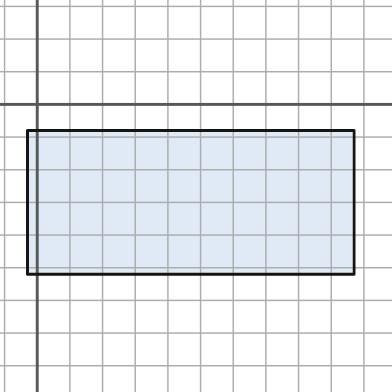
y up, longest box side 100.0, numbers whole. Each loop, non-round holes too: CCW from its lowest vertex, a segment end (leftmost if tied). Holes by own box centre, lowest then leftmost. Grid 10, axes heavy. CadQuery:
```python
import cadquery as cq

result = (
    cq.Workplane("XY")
    .moveTo(-3.0, -52.0)
    .lineTo(97.0, -52.0)
    .lineTo(97.0, -8.0)
    .lineTo(-3.0, -8.0)
    .close()
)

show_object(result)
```